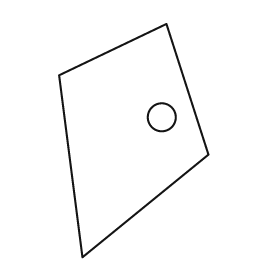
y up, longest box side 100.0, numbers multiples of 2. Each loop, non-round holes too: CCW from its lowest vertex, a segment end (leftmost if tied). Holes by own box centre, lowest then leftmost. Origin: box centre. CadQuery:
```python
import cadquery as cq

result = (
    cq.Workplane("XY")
    .moveTo(-22.0, -50.0)
    .lineTo(32.0, -6.0)
    .lineTo(14.0, 50.0)
    .lineTo(-32.0, 28.0)
    .close()
    .moveTo(12.0, 10.0)
    .circle(6.0)
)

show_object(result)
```